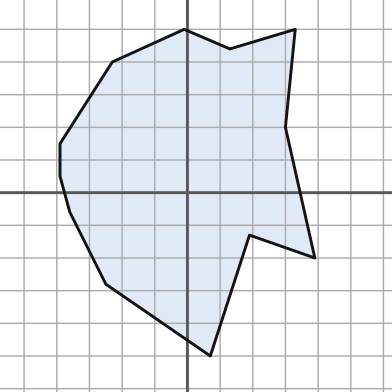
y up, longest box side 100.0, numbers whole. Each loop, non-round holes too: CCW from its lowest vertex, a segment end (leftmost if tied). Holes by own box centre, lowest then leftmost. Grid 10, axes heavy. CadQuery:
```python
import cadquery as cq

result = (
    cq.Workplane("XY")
    .moveTo(7.0, -50.0)
    .lineTo(19.0, -13.0)
    .lineTo(39.0, -20.0)
    .lineTo(30.0, 20.0)
    .lineTo(33.0, 50.0)
    .lineTo(13.0, 44.0)
    .lineTo(-1.0, 50.0)
    .lineTo(-23.0, 40.0)
    .lineTo(-39.0, 15.0)
    .lineTo(-39.0, 5.0)
    .lineTo(-36.0, -6.0)
    .lineTo(-25.0, -28.0)
    .close()
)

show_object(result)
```